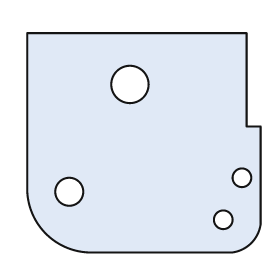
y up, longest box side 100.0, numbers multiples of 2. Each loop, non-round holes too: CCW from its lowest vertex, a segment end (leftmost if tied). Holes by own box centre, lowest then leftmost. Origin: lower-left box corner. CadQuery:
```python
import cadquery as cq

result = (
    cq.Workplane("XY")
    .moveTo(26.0, 0.0)
    .lineTo(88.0, 0.0)
    .threePointArc((96.0, 4.0), (100.0, 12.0))
    .lineTo(100.0, 54.0)
    .lineTo(94.0, 54.0)
    .lineTo(94.0, 94.0)
    .lineTo(0.0, 94.0)
    .lineTo(0.0, 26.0)
    .threePointArc((8.0, 8.0), (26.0, 0.0))
    .close()
    .moveTo(84.0, 14.0)
    .circle(4.0)
    .moveTo(18.0, 26.0)
    .circle(6.0)
    .moveTo(92.0, 32.0)
    .circle(4.0)
    .moveTo(44.0, 72.0)
    .circle(8.0)
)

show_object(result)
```